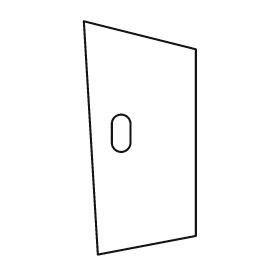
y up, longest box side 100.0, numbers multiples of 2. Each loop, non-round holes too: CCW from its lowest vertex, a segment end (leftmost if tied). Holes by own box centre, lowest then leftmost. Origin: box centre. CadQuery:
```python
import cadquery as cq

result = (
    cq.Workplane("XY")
    .moveTo(-18.0, -50.0)
    .lineTo(24.0, -42.0)
    .lineTo(24.0, 38.0)
    .lineTo(-24.0, 50.0)
    .close()
    .moveTo(-12.0, -2.0)
    .threePointArc((-8.0, -6.0), (-4.0, -2.0))
    .lineTo(-4.0, 6.0)
    .threePointArc((-8.0, 10.0), (-12.0, 6.0))
    .close()
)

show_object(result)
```